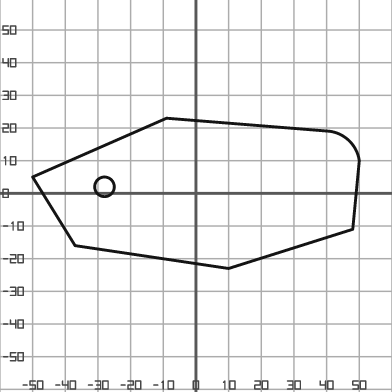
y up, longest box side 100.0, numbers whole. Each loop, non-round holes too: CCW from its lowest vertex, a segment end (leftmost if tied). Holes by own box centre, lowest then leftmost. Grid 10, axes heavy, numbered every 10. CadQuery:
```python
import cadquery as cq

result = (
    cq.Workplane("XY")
    .moveTo(10.0, -23.0)
    .lineTo(48.0, -11.0)
    .lineTo(50.0, 10.0)
    .threePointArc((47.0, 16.0), (41.0, 19.0))
    .lineTo(-9.0, 23.0)
    .lineTo(-50.0, 5.0)
    .lineTo(-37.0, -16.0)
    .close()
    .moveTo(-28.0, 2.0)
    .circle(3.0)
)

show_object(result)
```